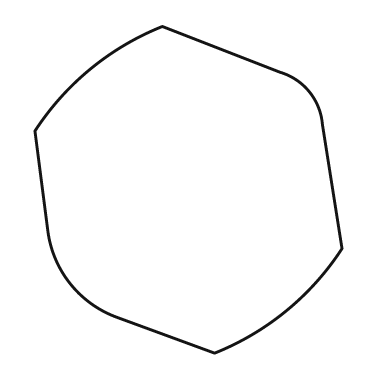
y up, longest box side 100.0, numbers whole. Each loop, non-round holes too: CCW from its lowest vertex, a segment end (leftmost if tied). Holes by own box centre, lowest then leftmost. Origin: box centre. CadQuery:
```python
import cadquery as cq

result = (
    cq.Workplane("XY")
    .moveTo(8.0, -50.0)
    .threePointArc((30.0, -37.0), (47.0, -18.0))
    .lineTo(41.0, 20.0)
    .threePointArc((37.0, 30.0), (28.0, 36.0))
    .lineTo(-8.0, 50.0)
    .threePointArc((-30.0, 37.0), (-47.0, 18.0))
    .lineTo(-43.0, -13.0)
    .threePointArc((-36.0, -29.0), (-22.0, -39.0))
    .close()
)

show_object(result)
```